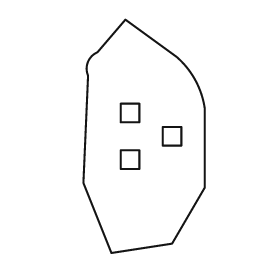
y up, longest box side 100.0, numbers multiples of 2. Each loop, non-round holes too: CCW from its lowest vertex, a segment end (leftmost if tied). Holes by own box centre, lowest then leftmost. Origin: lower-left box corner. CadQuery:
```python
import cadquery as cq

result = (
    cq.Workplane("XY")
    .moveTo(12.0, 0.0)
    .lineTo(38.0, 4.0)
    .lineTo(52.0, 28.0)
    .lineTo(52.0, 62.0)
    .threePointArc((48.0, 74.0), (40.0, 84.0))
    .lineTo(18.0, 100.0)
    .lineTo(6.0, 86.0)
    .threePointArc((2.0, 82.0), (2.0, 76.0))
    .lineTo(0.0, 30.0)
    .close()
    .moveTo(16.0, 36.0)
    .lineTo(24.0, 36.0)
    .lineTo(24.0, 44.0)
    .lineTo(16.0, 44.0)
    .close()
    .moveTo(34.0, 46.0)
    .lineTo(42.0, 46.0)
    .lineTo(42.0, 54.0)
    .lineTo(34.0, 54.0)
    .close()
    .moveTo(16.0, 56.0)
    .lineTo(24.0, 56.0)
    .lineTo(24.0, 64.0)
    .lineTo(16.0, 64.0)
    .close()
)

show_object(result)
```